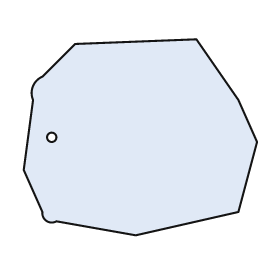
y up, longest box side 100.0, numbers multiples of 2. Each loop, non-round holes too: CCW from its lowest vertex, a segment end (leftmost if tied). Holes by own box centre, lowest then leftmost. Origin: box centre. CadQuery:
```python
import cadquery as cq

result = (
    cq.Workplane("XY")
    .moveTo(-2.0, -42.0)
    .lineTo(42.0, -32.0)
    .lineTo(50.0, -2.0)
    .lineTo(42.0, 16.0)
    .lineTo(24.0, 42.0)
    .lineTo(-28.0, 40.0)
    .lineTo(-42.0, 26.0)
    .threePointArc((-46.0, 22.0), (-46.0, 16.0))
    .lineTo(-50.0, -14.0)
    .lineTo(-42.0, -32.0)
    .threePointArc((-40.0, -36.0), (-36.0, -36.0))
    .close()
    .moveTo(-38.0, 0.0)
    .circle(2.0)
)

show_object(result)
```